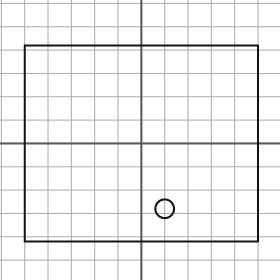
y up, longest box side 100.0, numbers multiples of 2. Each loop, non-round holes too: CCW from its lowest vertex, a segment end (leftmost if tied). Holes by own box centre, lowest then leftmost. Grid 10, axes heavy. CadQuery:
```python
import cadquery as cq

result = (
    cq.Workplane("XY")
    .moveTo(-50.0, -42.0)
    .lineTo(50.0, -42.0)
    .lineTo(50.0, 42.0)
    .lineTo(-50.0, 42.0)
    .close()
    .moveTo(10.0, -28.0)
    .circle(4.0)
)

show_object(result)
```